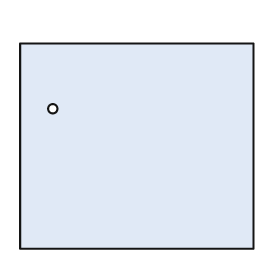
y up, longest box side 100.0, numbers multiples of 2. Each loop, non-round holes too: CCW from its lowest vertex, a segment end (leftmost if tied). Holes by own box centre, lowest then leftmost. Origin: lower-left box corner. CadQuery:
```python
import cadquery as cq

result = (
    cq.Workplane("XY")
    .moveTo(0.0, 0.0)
    .lineTo(100.0, 0.0)
    .lineTo(100.0, 88.0)
    .lineTo(0.0, 88.0)
    .close()
    .moveTo(14.0, 60.0)
    .circle(2.0)
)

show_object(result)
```